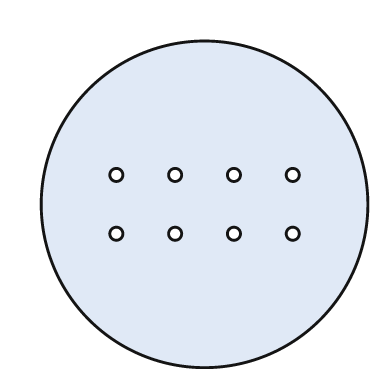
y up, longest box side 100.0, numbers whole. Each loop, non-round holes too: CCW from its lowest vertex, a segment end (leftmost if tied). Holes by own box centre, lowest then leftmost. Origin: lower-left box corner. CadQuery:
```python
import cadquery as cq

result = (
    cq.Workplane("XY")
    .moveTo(50.0, 50.0)
    .circle(50.0)
    .moveTo(23.0, 41.0)
    .circle(2.0)
    .moveTo(41.0, 41.0)
    .circle(2.0)
    .moveTo(59.0, 41.0)
    .circle(2.0)
    .moveTo(77.0, 41.0)
    .circle(2.0)
    .moveTo(23.0, 59.0)
    .circle(2.0)
    .moveTo(41.0, 59.0)
    .circle(2.0)
    .moveTo(59.0, 59.0)
    .circle(2.0)
    .moveTo(77.0, 59.0)
    .circle(2.0)
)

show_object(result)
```